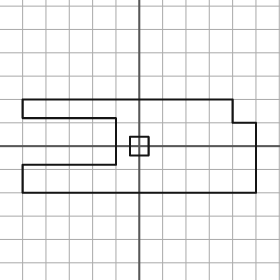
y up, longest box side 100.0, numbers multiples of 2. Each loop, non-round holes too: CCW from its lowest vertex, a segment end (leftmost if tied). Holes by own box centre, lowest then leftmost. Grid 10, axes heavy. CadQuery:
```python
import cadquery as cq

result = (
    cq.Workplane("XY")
    .moveTo(-50.0, -20.0)
    .lineTo(50.0, -20.0)
    .lineTo(50.0, 10.0)
    .lineTo(40.0, 10.0)
    .lineTo(40.0, 20.0)
    .lineTo(-50.0, 20.0)
    .lineTo(-50.0, 12.0)
    .lineTo(-10.0, 12.0)
    .lineTo(-10.0, -8.0)
    .lineTo(-50.0, -8.0)
    .close()
    .moveTo(-4.0, -4.0)
    .lineTo(4.0, -4.0)
    .lineTo(4.0, 4.0)
    .lineTo(-4.0, 4.0)
    .close()
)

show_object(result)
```